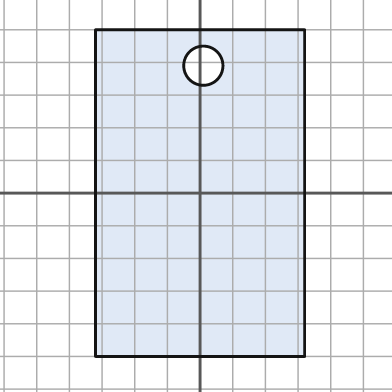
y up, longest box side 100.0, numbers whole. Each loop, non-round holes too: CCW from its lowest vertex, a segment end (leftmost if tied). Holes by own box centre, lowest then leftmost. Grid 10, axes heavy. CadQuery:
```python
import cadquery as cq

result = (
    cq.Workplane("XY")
    .moveTo(-32.0, -50.0)
    .lineTo(32.0, -50.0)
    .lineTo(32.0, 50.0)
    .lineTo(-32.0, 50.0)
    .close()
    .moveTo(1.0, 39.0)
    .circle(6.0)
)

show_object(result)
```